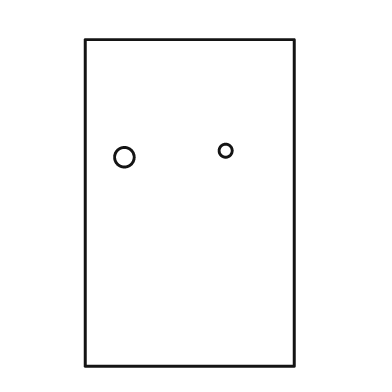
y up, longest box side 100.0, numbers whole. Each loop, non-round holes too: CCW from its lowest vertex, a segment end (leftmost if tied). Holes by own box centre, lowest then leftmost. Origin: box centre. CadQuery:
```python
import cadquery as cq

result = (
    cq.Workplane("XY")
    .moveTo(-32.0, -50.0)
    .lineTo(32.0, -50.0)
    .lineTo(32.0, 50.0)
    .lineTo(-32.0, 50.0)
    .close()
    .moveTo(-20.0, 14.0)
    .circle(3.0)
    .moveTo(11.0, 16.0)
    .circle(2.0)
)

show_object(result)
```